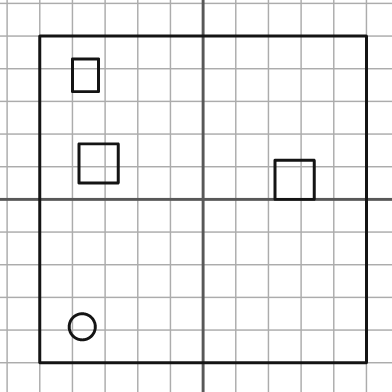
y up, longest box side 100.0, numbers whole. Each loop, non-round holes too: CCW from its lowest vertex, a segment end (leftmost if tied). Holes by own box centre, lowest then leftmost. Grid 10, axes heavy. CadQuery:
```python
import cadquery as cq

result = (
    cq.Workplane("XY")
    .moveTo(-50.0, -50.0)
    .lineTo(50.0, -50.0)
    .lineTo(50.0, 50.0)
    .lineTo(-50.0, 50.0)
    .close()
    .moveTo(-37.0, -39.0)
    .circle(4.0)
    .moveTo(22.0, 0.0)
    .lineTo(34.0, 0.0)
    .lineTo(34.0, 12.0)
    .lineTo(22.0, 12.0)
    .close()
    .moveTo(-38.0, 5.0)
    .lineTo(-26.0, 5.0)
    .lineTo(-26.0, 17.0)
    .lineTo(-38.0, 17.0)
    .close()
    .moveTo(-40.0, 33.0)
    .lineTo(-32.0, 33.0)
    .lineTo(-32.0, 43.0)
    .lineTo(-40.0, 43.0)
    .close()
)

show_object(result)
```